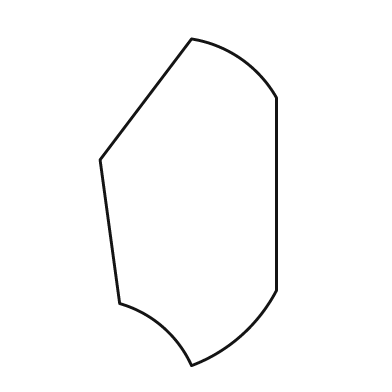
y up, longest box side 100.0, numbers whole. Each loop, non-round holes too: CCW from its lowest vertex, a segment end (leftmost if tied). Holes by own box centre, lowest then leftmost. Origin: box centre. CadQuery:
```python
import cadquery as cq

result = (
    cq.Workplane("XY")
    .moveTo(1.0, -50.0)
    .threePointArc((16.0, -41.0), (27.0, -27.0))
    .lineTo(27.0, 32.0)
    .threePointArc((16.0, 44.0), (1.0, 50.0))
    .lineTo(-27.0, 13.0)
    .lineTo(-21.0, -31.0)
    .threePointArc((-8.0, -38.0), (1.0, -50.0))
    .close()
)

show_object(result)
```